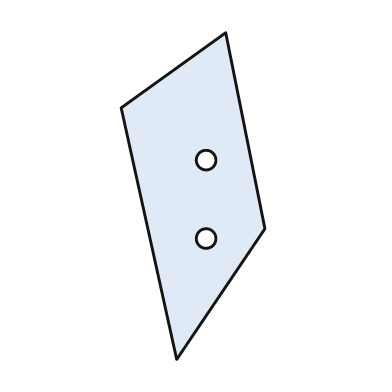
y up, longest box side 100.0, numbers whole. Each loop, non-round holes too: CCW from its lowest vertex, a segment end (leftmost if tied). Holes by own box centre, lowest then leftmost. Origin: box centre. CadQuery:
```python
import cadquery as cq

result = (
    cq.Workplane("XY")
    .moveTo(-5.0, -50.0)
    .lineTo(22.0, -10.0)
    .lineTo(10.0, 50.0)
    .lineTo(-22.0, 27.0)
    .close()
    .moveTo(4.0, -13.0)
    .circle(3.0)
    .moveTo(4.0, 11.0)
    .circle(3.0)
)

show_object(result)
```